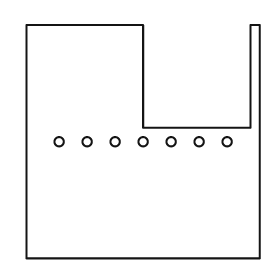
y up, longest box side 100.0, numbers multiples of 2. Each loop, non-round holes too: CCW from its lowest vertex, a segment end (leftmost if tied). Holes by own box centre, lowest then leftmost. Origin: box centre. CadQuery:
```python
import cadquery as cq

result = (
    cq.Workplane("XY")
    .moveTo(-50.0, -50.0)
    .lineTo(50.0, -50.0)
    .lineTo(50.0, 50.0)
    .lineTo(46.0, 50.0)
    .lineTo(46.0, 6.0)
    .lineTo(0.0, 6.0)
    .lineTo(0.0, 50.0)
    .lineTo(-50.0, 50.0)
    .close()
    .moveTo(-36.0, 0.0)
    .circle(2.0)
    .moveTo(-24.0, 0.0)
    .circle(2.0)
    .moveTo(-12.0, 0.0)
    .circle(2.0)
    .moveTo(0.0, 0.0)
    .circle(2.0)
    .moveTo(12.0, 0.0)
    .circle(2.0)
    .moveTo(24.0, 0.0)
    .circle(2.0)
    .moveTo(36.0, 0.0)
    .circle(2.0)
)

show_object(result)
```